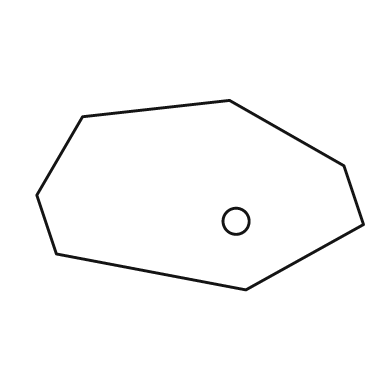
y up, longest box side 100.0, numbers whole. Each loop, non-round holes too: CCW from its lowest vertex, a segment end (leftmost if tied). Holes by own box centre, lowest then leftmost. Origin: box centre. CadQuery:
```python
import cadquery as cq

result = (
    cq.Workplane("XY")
    .moveTo(14.0, -29.0)
    .lineTo(50.0, -9.0)
    .lineTo(44.0, 9.0)
    .lineTo(9.0, 29.0)
    .lineTo(-36.0, 24.0)
    .lineTo(-50.0, 0.0)
    .lineTo(-44.0, -18.0)
    .close()
    .moveTo(11.0, -8.0)
    .circle(4.0)
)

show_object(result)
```